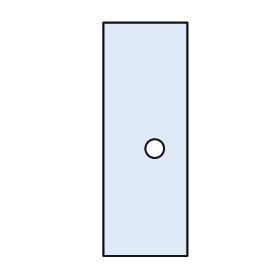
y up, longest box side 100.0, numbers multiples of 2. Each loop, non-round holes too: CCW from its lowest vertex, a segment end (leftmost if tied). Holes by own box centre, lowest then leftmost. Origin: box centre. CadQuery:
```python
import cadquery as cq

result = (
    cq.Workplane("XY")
    .moveTo(-18.0, -50.0)
    .lineTo(18.0, -50.0)
    .lineTo(18.0, 50.0)
    .lineTo(-18.0, 50.0)
    .close()
    .moveTo(4.0, -4.0)
    .circle(4.0)
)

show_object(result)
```